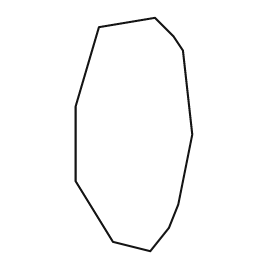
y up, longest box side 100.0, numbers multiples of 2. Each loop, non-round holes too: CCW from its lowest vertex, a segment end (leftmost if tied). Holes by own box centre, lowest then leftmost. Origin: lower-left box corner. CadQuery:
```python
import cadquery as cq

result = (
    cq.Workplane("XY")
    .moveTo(32.0, 0.0)
    .lineTo(40.0, 10.0)
    .lineTo(44.0, 20.0)
    .lineTo(50.0, 50.0)
    .lineTo(46.0, 86.0)
    .lineTo(42.0, 92.0)
    .lineTo(34.0, 100.0)
    .lineTo(10.0, 96.0)
    .lineTo(0.0, 62.0)
    .lineTo(0.0, 30.0)
    .lineTo(16.0, 4.0)
    .close()
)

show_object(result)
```